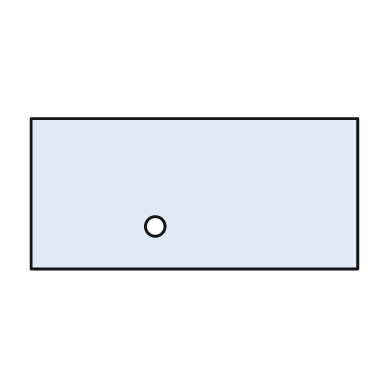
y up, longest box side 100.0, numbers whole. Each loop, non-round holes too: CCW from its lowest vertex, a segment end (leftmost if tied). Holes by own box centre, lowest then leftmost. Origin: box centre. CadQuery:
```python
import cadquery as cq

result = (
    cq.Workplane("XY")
    .moveTo(-50.0, -23.0)
    .lineTo(50.0, -23.0)
    .lineTo(50.0, 23.0)
    .lineTo(-50.0, 23.0)
    .close()
    .moveTo(-12.0, -10.0)
    .circle(3.0)
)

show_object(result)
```